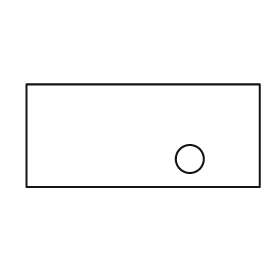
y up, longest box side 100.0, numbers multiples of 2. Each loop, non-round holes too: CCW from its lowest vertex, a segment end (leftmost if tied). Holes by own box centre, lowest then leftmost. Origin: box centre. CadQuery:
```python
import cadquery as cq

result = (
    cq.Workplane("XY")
    .moveTo(-50.0, -22.0)
    .lineTo(50.0, -22.0)
    .lineTo(50.0, 22.0)
    .lineTo(-50.0, 22.0)
    .close()
    .moveTo(20.0, -10.0)
    .circle(6.0)
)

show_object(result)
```